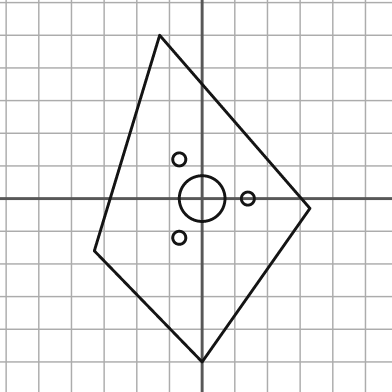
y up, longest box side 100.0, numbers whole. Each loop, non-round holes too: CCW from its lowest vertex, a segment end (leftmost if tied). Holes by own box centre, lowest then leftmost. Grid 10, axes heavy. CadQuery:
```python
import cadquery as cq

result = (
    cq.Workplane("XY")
    .moveTo(0.0, -50.0)
    .lineTo(33.0, -3.0)
    .lineTo(-13.0, 50.0)
    .lineTo(-33.0, -16.0)
    .close()
    .moveTo(-7.0, -12.0)
    .circle(2.0)
    .moveTo(0.0, 0.0)
    .circle(7.0)
    .moveTo(14.0, 0.0)
    .circle(2.0)
    .moveTo(-7.0, 12.0)
    .circle(2.0)
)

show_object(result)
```